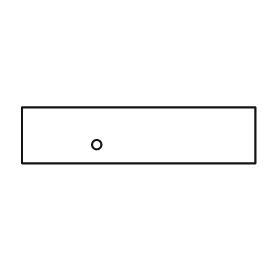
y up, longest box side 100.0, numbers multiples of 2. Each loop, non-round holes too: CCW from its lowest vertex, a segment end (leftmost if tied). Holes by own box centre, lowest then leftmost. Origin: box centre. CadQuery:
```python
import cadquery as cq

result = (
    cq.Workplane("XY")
    .moveTo(-50.0, -12.0)
    .lineTo(50.0, -12.0)
    .lineTo(50.0, 12.0)
    .lineTo(-50.0, 12.0)
    .close()
    .moveTo(-18.0, -4.0)
    .circle(2.0)
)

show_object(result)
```